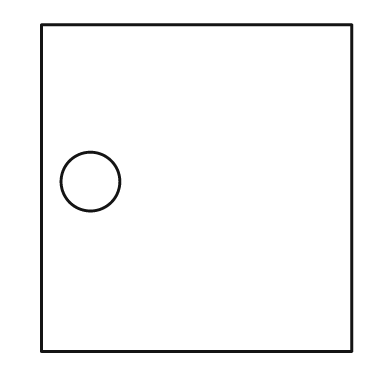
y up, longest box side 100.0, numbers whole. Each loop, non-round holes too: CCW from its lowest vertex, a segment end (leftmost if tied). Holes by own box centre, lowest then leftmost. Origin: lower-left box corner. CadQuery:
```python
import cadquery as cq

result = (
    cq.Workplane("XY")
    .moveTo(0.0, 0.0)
    .lineTo(95.0, 0.0)
    .lineTo(95.0, 100.0)
    .lineTo(0.0, 100.0)
    .close()
    .moveTo(15.0, 52.0)
    .circle(9.0)
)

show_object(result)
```